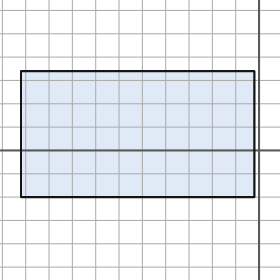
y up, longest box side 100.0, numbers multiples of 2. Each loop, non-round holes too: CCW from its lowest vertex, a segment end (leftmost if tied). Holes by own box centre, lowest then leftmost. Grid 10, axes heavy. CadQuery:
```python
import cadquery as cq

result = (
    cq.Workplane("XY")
    .moveTo(-102.0, -20.0)
    .lineTo(-2.0, -20.0)
    .lineTo(-2.0, 34.0)
    .lineTo(-102.0, 34.0)
    .close()
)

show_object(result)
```